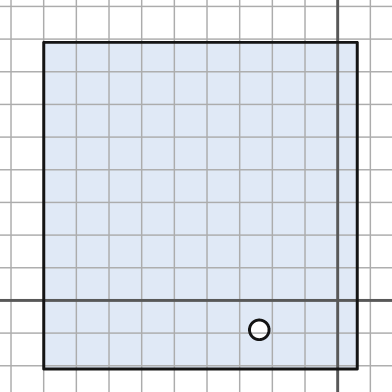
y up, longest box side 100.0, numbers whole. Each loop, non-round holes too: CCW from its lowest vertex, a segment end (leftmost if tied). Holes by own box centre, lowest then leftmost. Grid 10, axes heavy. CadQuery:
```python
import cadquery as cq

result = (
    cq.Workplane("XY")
    .moveTo(-90.0, -21.0)
    .lineTo(6.0, -21.0)
    .lineTo(6.0, 79.0)
    .lineTo(-90.0, 79.0)
    .close()
    .moveTo(-24.0, -9.0)
    .circle(3.0)
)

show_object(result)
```